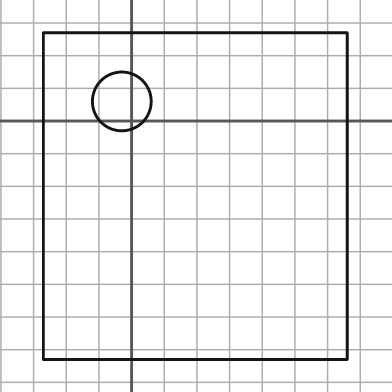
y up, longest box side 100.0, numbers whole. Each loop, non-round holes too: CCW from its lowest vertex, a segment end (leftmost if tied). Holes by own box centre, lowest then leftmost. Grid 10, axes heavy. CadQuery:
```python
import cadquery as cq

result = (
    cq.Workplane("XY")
    .moveTo(-27.0, -73.0)
    .lineTo(66.0, -73.0)
    .lineTo(66.0, 27.0)
    .lineTo(-27.0, 27.0)
    .close()
    .moveTo(-3.0, 6.0)
    .circle(9.0)
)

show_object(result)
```